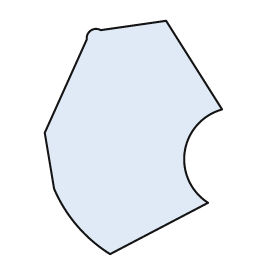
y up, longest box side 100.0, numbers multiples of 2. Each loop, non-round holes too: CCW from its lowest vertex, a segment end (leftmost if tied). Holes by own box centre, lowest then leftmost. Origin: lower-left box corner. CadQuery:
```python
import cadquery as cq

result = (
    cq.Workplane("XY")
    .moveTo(28.0, 0.0)
    .lineTo(70.0, 22.0)
    .threePointArc((60.0, 44.0), (76.0, 62.0))
    .lineTo(52.0, 100.0)
    .lineTo(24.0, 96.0)
    .threePointArc((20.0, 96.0), (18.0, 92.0))
    .lineTo(0.0, 52.0)
    .lineTo(4.0, 28.0)
    .threePointArc((14.0, 12.0), (28.0, 0.0))
    .close()
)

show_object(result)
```